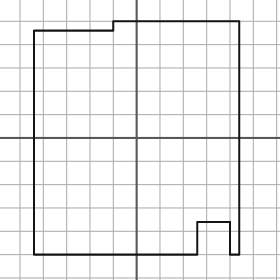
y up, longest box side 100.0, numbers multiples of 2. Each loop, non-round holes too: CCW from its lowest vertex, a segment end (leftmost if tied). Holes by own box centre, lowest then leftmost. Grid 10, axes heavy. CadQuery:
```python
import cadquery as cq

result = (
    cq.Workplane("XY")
    .moveTo(-44.0, -50.0)
    .lineTo(26.0, -50.0)
    .lineTo(26.0, -36.0)
    .lineTo(40.0, -36.0)
    .lineTo(40.0, -50.0)
    .lineTo(44.0, -50.0)
    .lineTo(44.0, 50.0)
    .lineTo(-10.0, 50.0)
    .lineTo(-10.0, 46.0)
    .lineTo(-44.0, 46.0)
    .close()
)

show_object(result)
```